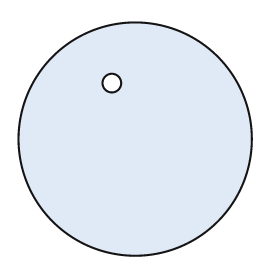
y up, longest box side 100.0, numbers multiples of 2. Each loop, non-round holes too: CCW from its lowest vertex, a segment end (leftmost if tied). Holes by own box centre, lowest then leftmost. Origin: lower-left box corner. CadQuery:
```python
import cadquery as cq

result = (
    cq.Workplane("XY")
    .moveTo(50.0, 50.0)
    .circle(50.0)
    .moveTo(40.0, 74.0)
    .circle(4.0)
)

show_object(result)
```